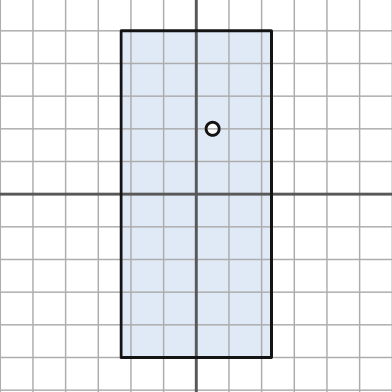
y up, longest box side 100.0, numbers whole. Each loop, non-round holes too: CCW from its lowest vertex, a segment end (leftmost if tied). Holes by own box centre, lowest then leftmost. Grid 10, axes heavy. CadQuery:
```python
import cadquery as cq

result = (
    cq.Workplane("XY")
    .moveTo(-23.0, -50.0)
    .lineTo(23.0, -50.0)
    .lineTo(23.0, 50.0)
    .lineTo(-23.0, 50.0)
    .close()
    .moveTo(5.0, 20.0)
    .circle(2.0)
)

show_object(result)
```